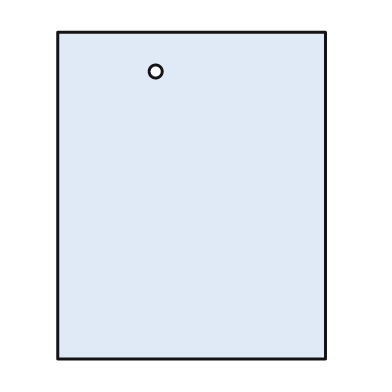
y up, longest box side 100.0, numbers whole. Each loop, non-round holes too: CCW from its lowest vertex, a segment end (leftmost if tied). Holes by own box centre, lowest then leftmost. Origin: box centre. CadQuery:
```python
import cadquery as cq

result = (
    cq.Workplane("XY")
    .moveTo(-41.0, -50.0)
    .lineTo(41.0, -50.0)
    .lineTo(41.0, 50.0)
    .lineTo(-41.0, 50.0)
    .close()
    .moveTo(-11.0, 38.0)
    .circle(2.0)
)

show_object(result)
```